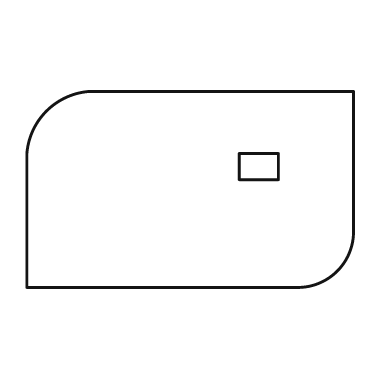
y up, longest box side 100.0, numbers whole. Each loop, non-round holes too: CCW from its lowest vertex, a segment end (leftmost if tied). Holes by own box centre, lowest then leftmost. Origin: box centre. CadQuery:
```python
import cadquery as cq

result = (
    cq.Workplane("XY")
    .moveTo(-50.0, -30.0)
    .lineTo(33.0, -30.0)
    .threePointArc((45.0, -25.0), (50.0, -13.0))
    .lineTo(50.0, 30.0)
    .lineTo(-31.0, 30.0)
    .threePointArc((-44.0, 24.0), (-50.0, 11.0))
    .close()
    .moveTo(15.0, 3.0)
    .lineTo(27.0, 3.0)
    .lineTo(27.0, 11.0)
    .lineTo(15.0, 11.0)
    .close()
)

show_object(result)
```